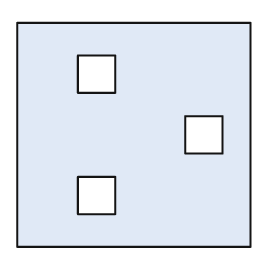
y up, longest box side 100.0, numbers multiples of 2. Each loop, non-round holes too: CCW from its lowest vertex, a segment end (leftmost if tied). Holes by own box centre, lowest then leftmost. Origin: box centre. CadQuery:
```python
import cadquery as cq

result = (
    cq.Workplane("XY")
    .moveTo(-50.0, -48.0)
    .lineTo(50.0, -48.0)
    .lineTo(50.0, 48.0)
    .lineTo(-50.0, 48.0)
    .close()
    .moveTo(-24.0, -34.0)
    .lineTo(-8.0, -34.0)
    .lineTo(-8.0, -18.0)
    .lineTo(-24.0, -18.0)
    .close()
    .moveTo(22.0, -8.0)
    .lineTo(38.0, -8.0)
    .lineTo(38.0, 8.0)
    .lineTo(22.0, 8.0)
    .close()
    .moveTo(-24.0, 18.0)
    .lineTo(-8.0, 18.0)
    .lineTo(-8.0, 34.0)
    .lineTo(-24.0, 34.0)
    .close()
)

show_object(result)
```